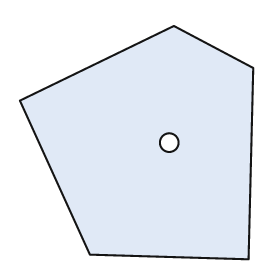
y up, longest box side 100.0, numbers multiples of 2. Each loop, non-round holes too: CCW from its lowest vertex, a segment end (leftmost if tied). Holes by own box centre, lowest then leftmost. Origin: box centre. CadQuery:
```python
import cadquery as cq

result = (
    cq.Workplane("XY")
    .moveTo(48.0, -50.0)
    .lineTo(50.0, 32.0)
    .lineTo(16.0, 50.0)
    .lineTo(-50.0, 18.0)
    .lineTo(-20.0, -48.0)
    .close()
    .moveTo(14.0, 0.0)
    .circle(4.0)
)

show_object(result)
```